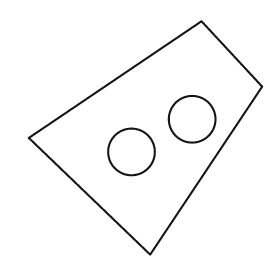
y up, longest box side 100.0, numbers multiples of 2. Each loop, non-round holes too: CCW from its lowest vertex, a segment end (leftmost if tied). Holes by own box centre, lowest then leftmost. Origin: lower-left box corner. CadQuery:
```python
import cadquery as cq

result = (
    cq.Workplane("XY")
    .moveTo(52.0, 0.0)
    .lineTo(100.0, 72.0)
    .lineTo(74.0, 100.0)
    .lineTo(0.0, 50.0)
    .close()
    .moveTo(44.0, 44.0)
    .circle(10.0)
    .moveTo(70.0, 58.0)
    .circle(10.0)
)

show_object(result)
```